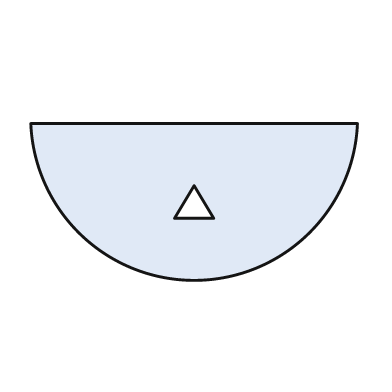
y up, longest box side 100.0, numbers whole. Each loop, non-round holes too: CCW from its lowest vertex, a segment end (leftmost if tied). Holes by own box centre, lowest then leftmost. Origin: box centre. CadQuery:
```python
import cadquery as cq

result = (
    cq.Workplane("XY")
    .moveTo(-50.0, 24.0)
    .threePointArc((0.0, -24.0), (50.0, 24.0))
    .close()
    .moveTo(-6.0, -5.0)
    .lineTo(6.0, -5.0)
    .lineTo(0.0, 5.0)
    .close()
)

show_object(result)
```